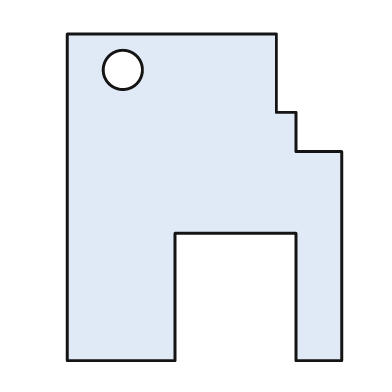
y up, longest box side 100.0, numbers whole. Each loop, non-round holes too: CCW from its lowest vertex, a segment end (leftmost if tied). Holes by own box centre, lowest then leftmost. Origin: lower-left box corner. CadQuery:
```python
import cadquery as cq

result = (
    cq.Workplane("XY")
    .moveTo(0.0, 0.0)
    .lineTo(33.0, 0.0)
    .lineTo(33.0, 39.0)
    .lineTo(70.0, 39.0)
    .lineTo(70.0, 0.0)
    .lineTo(84.0, 0.0)
    .lineTo(84.0, 64.0)
    .lineTo(70.0, 64.0)
    .lineTo(70.0, 76.0)
    .lineTo(64.0, 76.0)
    .lineTo(64.0, 100.0)
    .lineTo(0.0, 100.0)
    .close()
    .moveTo(17.0, 89.0)
    .circle(6.0)
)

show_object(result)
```